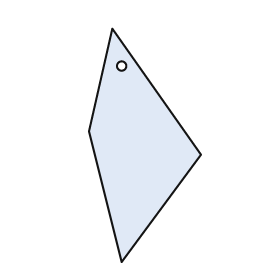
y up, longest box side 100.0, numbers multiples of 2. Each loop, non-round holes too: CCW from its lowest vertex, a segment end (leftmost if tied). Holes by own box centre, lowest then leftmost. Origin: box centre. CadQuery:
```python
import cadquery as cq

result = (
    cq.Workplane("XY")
    .moveTo(-10.0, -50.0)
    .lineTo(24.0, -4.0)
    .lineTo(-14.0, 50.0)
    .lineTo(-24.0, 6.0)
    .close()
    .moveTo(-10.0, 34.0)
    .circle(2.0)
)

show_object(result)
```